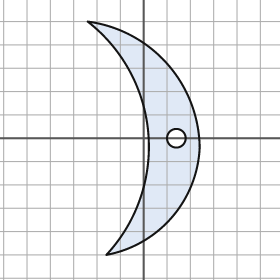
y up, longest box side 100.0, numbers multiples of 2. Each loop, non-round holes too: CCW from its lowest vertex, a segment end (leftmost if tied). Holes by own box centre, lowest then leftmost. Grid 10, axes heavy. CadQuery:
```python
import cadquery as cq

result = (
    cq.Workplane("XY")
    .moveTo(-16.0, -50.0)
    .threePointArc((12.0, -34.0), (24.0, -4.0))
    .threePointArc((10.0, 32.0), (-24.0, 50.0))
    .threePointArc((2.0, 2.0), (-16.0, -50.0))
    .close()
    .moveTo(14.0, 0.0)
    .circle(4.0)
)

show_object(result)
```